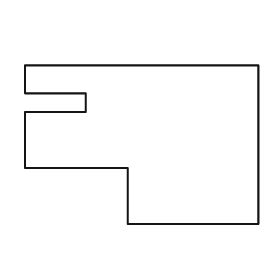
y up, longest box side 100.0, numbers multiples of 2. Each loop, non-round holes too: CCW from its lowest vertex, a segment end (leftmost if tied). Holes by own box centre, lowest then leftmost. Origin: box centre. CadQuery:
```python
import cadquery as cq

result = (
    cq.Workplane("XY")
    .moveTo(-6.0, -34.0)
    .lineTo(50.0, -34.0)
    .lineTo(50.0, 34.0)
    .lineTo(-50.0, 34.0)
    .lineTo(-50.0, 22.0)
    .lineTo(-24.0, 22.0)
    .lineTo(-24.0, 14.0)
    .lineTo(-50.0, 14.0)
    .lineTo(-50.0, -10.0)
    .lineTo(-6.0, -10.0)
    .close()
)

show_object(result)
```